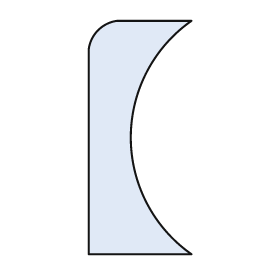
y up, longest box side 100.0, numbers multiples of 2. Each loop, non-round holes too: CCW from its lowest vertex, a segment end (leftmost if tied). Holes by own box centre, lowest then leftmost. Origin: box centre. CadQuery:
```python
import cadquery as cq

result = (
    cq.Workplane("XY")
    .moveTo(-22.0, -50.0)
    .lineTo(22.0, -50.0)
    .threePointArc((-4.0, 0.0), (22.0, 50.0))
    .lineTo(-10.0, 50.0)
    .threePointArc((-18.0, 46.0), (-22.0, 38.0))
    .close()
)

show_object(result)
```